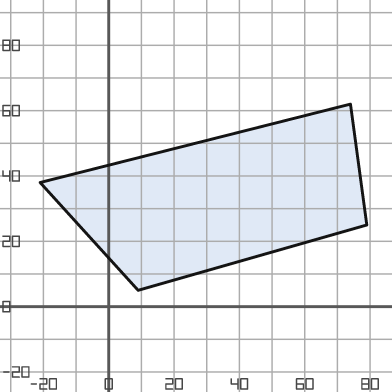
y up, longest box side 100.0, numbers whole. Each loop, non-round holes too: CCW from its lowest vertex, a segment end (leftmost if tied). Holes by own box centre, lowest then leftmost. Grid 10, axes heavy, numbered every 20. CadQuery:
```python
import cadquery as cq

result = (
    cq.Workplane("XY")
    .moveTo(9.0, 5.0)
    .lineTo(79.0, 25.0)
    .lineTo(74.0, 62.0)
    .lineTo(-21.0, 38.0)
    .close()
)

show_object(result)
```